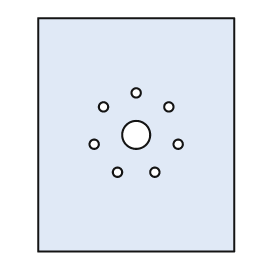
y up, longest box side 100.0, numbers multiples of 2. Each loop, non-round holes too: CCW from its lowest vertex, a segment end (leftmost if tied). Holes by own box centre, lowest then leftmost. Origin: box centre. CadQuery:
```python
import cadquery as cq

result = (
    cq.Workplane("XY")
    .moveTo(-42.0, -50.0)
    .lineTo(42.0, -50.0)
    .lineTo(42.0, 50.0)
    .lineTo(-42.0, 50.0)
    .close()
    .moveTo(-8.0, -16.0)
    .circle(2.0)
    .moveTo(8.0, -16.0)
    .circle(2.0)
    .moveTo(-18.0, -4.0)
    .circle(2.0)
    .moveTo(18.0, -4.0)
    .circle(2.0)
    .moveTo(0.0, 0.0)
    .circle(6.0)
    .moveTo(-14.0, 12.0)
    .circle(2.0)
    .moveTo(14.0, 12.0)
    .circle(2.0)
    .moveTo(0.0, 18.0)
    .circle(2.0)
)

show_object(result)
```